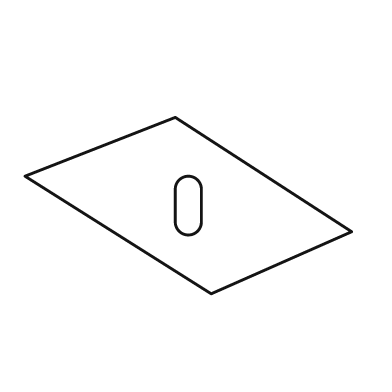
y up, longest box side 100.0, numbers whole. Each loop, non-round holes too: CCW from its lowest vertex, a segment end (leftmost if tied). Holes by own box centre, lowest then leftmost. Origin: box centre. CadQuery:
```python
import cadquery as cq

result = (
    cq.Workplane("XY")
    .moveTo(7.0, -27.0)
    .lineTo(50.0, -8.0)
    .lineTo(-4.0, 27.0)
    .lineTo(-50.0, 9.0)
    .close()
    .moveTo(-4.0, -5.0)
    .threePointArc((0.0, -9.0), (4.0, -5.0))
    .lineTo(4.0, 5.0)
    .threePointArc((0.0, 9.0), (-4.0, 5.0))
    .close()
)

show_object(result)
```